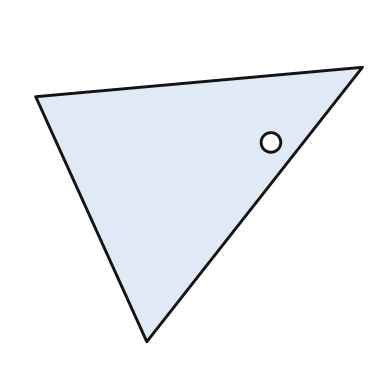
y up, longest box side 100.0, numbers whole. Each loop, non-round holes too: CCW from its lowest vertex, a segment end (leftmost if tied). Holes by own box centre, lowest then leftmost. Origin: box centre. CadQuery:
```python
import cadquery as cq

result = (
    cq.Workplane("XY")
    .moveTo(-16.0, -42.0)
    .lineTo(50.0, 42.0)
    .lineTo(-50.0, 33.0)
    .close()
    .moveTo(22.0, 19.0)
    .circle(3.0)
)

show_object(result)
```